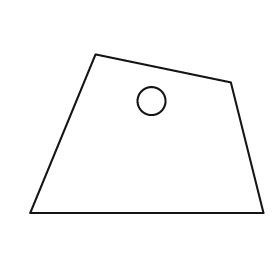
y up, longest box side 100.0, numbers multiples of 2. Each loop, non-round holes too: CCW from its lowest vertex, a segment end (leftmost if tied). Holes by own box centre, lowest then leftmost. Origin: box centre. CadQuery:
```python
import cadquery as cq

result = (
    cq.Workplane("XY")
    .moveTo(-50.0, -34.0)
    .lineTo(50.0, -34.0)
    .lineTo(36.0, 22.0)
    .lineTo(-22.0, 34.0)
    .close()
    .moveTo(2.0, 14.0)
    .circle(6.0)
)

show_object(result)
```